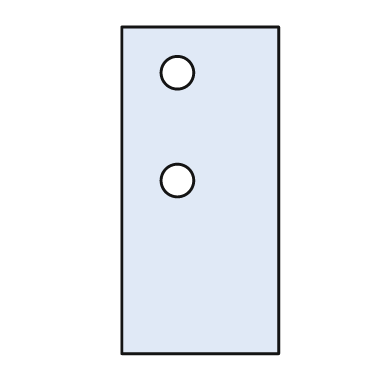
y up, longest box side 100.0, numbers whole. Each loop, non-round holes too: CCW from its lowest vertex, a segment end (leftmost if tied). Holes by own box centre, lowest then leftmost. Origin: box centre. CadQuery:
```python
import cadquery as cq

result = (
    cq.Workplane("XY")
    .moveTo(-24.0, -50.0)
    .lineTo(24.0, -50.0)
    .lineTo(24.0, 50.0)
    .lineTo(-24.0, 50.0)
    .close()
    .moveTo(-7.0, 3.0)
    .circle(5.0)
    .moveTo(-7.0, 36.0)
    .circle(5.0)
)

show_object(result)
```